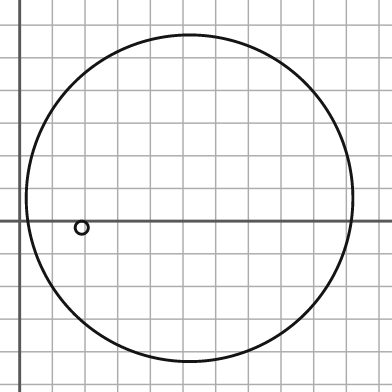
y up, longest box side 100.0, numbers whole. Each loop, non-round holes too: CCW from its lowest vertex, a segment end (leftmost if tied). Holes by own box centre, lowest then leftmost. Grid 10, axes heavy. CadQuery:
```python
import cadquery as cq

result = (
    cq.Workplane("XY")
    .moveTo(52.0, 7.0)
    .circle(50.0)
    .moveTo(19.0, -2.0)
    .circle(2.0)
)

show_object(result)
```